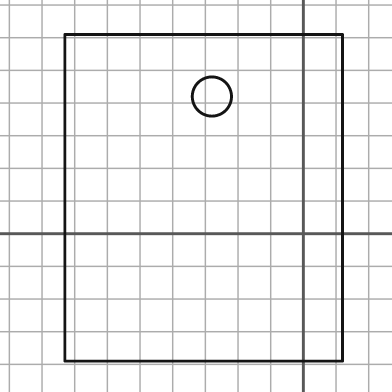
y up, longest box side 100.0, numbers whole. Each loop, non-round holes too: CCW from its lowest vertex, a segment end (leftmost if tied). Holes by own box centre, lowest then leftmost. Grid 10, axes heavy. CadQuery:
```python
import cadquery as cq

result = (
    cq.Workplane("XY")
    .moveTo(-73.0, -39.0)
    .lineTo(12.0, -39.0)
    .lineTo(12.0, 61.0)
    .lineTo(-73.0, 61.0)
    .close()
    .moveTo(-28.0, 42.0)
    .circle(6.0)
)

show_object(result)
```